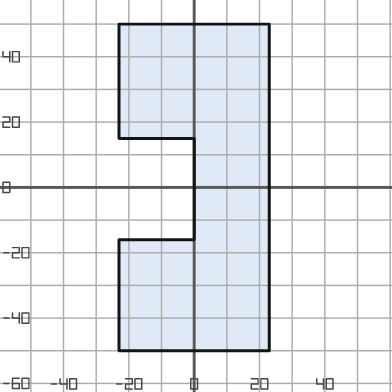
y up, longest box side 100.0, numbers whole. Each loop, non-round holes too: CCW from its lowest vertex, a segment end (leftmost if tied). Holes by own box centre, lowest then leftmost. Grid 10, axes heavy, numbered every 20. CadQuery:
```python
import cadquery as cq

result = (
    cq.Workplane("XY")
    .moveTo(-23.0, -50.0)
    .lineTo(23.0, -50.0)
    .lineTo(23.0, 50.0)
    .lineTo(-23.0, 50.0)
    .lineTo(-23.0, 15.0)
    .lineTo(0.0, 15.0)
    .lineTo(0.0, -16.0)
    .lineTo(-23.0, -16.0)
    .close()
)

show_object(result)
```